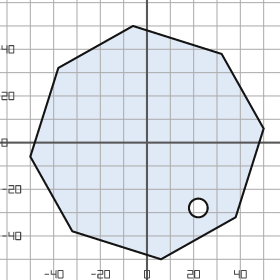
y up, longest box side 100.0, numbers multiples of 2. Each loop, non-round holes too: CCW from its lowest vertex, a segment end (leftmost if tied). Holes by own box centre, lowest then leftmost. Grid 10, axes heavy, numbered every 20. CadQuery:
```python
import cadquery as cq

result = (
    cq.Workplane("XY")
    .moveTo(6.0, -50.0)
    .lineTo(38.0, -32.0)
    .lineTo(50.0, 6.0)
    .lineTo(32.0, 38.0)
    .lineTo(-6.0, 50.0)
    .lineTo(-38.0, 32.0)
    .lineTo(-50.0, -6.0)
    .lineTo(-32.0, -38.0)
    .close()
    .moveTo(22.0, -28.0)
    .circle(4.0)
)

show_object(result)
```